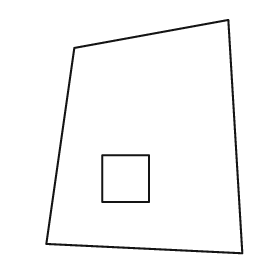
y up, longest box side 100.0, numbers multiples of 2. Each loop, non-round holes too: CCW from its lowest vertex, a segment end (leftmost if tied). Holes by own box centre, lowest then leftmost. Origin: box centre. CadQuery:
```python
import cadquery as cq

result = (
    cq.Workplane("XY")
    .moveTo(42.0, -50.0)
    .lineTo(36.0, 50.0)
    .lineTo(-30.0, 38.0)
    .lineTo(-42.0, -46.0)
    .close()
    .moveTo(-18.0, -28.0)
    .lineTo(2.0, -28.0)
    .lineTo(2.0, -8.0)
    .lineTo(-18.0, -8.0)
    .close()
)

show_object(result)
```